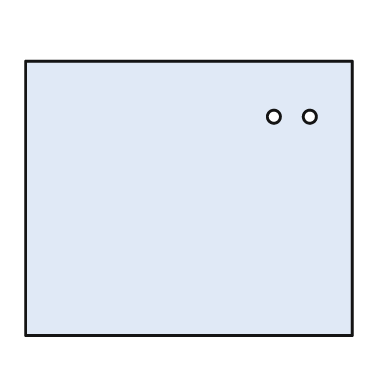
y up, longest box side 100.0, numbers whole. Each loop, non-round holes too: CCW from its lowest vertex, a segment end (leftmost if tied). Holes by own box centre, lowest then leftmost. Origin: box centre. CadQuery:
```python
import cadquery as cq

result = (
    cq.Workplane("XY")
    .moveTo(-50.0, -42.0)
    .lineTo(50.0, -42.0)
    .lineTo(50.0, 42.0)
    .lineTo(-50.0, 42.0)
    .close()
    .moveTo(26.0, 25.0)
    .circle(2.0)
    .moveTo(37.0, 25.0)
    .circle(2.0)
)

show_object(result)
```